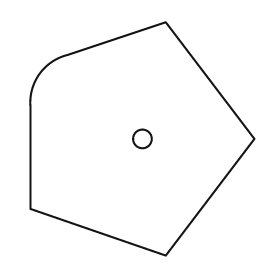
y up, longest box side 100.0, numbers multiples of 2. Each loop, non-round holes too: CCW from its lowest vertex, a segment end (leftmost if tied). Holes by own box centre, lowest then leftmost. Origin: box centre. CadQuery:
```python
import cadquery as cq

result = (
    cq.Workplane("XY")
    .moveTo(10.0, -50.0)
    .lineTo(48.0, 0.0)
    .lineTo(10.0, 50.0)
    .lineTo(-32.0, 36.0)
    .threePointArc((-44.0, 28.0), (-48.0, 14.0))
    .lineTo(-48.0, -30.0)
    .close()
    .moveTo(0.0, 0.0)
    .circle(4.0)
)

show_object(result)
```